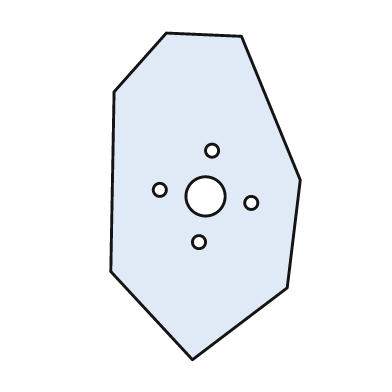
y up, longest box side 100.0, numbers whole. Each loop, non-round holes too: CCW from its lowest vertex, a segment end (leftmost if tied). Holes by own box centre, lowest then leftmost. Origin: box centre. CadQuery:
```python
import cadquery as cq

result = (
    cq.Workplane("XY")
    .moveTo(-4.0, -50.0)
    .lineTo(25.0, -28.0)
    .lineTo(29.0, 5.0)
    .lineTo(11.0, 49.0)
    .lineTo(-12.0, 50.0)
    .lineTo(-28.0, 32.0)
    .lineTo(-29.0, -23.0)
    .close()
    .moveTo(-2.0, -14.0)
    .circle(2.0)
    .moveTo(14.0, -2.0)
    .circle(2.0)
    .moveTo(0.0, 0.0)
    .circle(6.0)
    .moveTo(-14.0, 2.0)
    .circle(2.0)
    .moveTo(2.0, 14.0)
    .circle(2.0)
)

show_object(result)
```